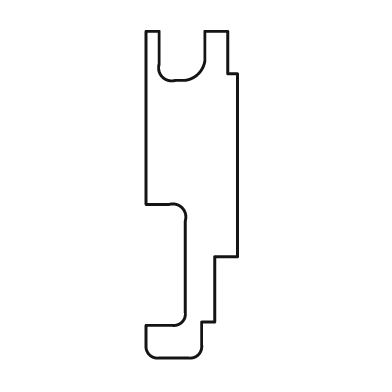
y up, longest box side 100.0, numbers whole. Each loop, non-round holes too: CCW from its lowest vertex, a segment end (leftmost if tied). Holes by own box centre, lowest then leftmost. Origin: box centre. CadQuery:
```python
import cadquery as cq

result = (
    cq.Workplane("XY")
    .moveTo(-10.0, -50.0)
    .lineTo(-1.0, -50.0)
    .threePointArc((2.0, -49.0), (3.0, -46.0))
    .lineTo(3.0, -39.0)
    .lineTo(7.0, -39.0)
    .lineTo(7.0, -19.0)
    .lineTo(14.0, -19.0)
    .lineTo(14.0, 37.0)
    .lineTo(11.0, 37.0)
    .lineTo(11.0, 50.0)
    .lineTo(4.0, 50.0)
    .lineTo(4.0, 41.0)
    .threePointArc((2.0, 37.0), (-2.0, 35.0))
    .lineTo(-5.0, 35.0)
    .threePointArc((-9.0, 36.0), (-10.0, 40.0))
    .lineTo(-10.0, 50.0)
    .lineTo(-14.0, 50.0)
    .lineTo(-14.0, -3.0)
    .lineTo(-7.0, -3.0)
    .threePointArc((-3.0, -4.0), (-2.0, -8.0))
    .lineTo(-2.0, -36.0)
    .threePointArc((-3.0, -39.0), (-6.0, -40.0))
    .lineTo(-14.0, -40.0)
    .lineTo(-14.0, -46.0)
    .threePointArc((-13.0, -49.0), (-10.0, -50.0))
    .close()
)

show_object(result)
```